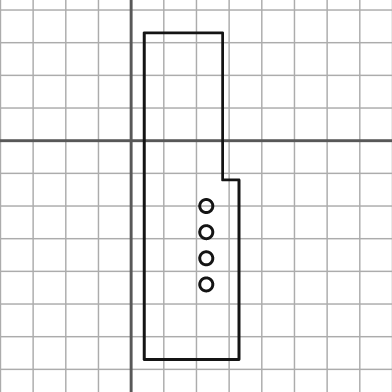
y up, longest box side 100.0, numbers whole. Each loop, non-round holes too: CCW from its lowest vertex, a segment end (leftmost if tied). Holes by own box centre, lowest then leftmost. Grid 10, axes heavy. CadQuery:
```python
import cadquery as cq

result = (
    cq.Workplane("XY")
    .moveTo(4.0, -67.0)
    .lineTo(33.0, -67.0)
    .lineTo(33.0, -12.0)
    .lineTo(28.0, -12.0)
    .lineTo(28.0, 33.0)
    .lineTo(4.0, 33.0)
    .close()
    .moveTo(23.0, -44.0)
    .circle(2.0)
    .moveTo(23.0, -36.0)
    .circle(2.0)
    .moveTo(23.0, -28.0)
    .circle(2.0)
    .moveTo(23.0, -20.0)
    .circle(2.0)
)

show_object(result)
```